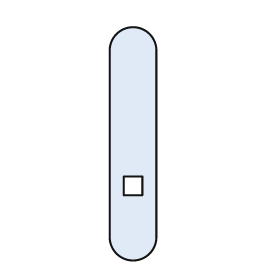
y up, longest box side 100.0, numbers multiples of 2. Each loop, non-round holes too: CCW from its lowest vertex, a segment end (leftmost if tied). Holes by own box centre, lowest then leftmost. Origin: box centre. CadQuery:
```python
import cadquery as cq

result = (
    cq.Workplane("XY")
    .moveTo(-10.0, -40.0)
    .threePointArc((0.0, -50.0), (10.0, -40.0))
    .lineTo(10.0, 40.0)
    .threePointArc((0.0, 50.0), (-10.0, 40.0))
    .close()
    .moveTo(-4.0, -22.0)
    .lineTo(4.0, -22.0)
    .lineTo(4.0, -14.0)
    .lineTo(-4.0, -14.0)
    .close()
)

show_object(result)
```